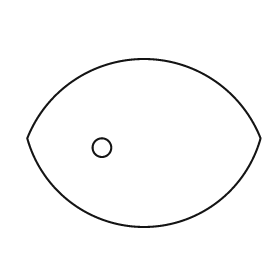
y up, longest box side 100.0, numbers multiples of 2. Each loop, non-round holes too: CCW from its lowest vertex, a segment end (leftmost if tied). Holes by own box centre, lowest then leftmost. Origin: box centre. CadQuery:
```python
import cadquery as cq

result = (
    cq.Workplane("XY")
    .moveTo(-50.0, 2.0)
    .threePointArc((0.0, -36.0), (50.0, 2.0))
    .threePointArc((0.0, 36.0), (-50.0, 2.0))
    .close()
    .moveTo(-18.0, -2.0)
    .circle(4.0)
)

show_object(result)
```